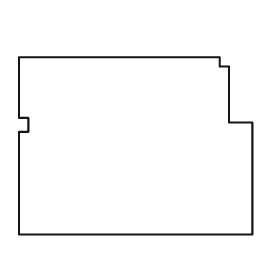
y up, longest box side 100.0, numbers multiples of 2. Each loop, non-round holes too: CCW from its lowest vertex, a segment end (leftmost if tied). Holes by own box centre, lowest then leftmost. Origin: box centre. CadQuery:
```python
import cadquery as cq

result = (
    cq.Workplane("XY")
    .moveTo(-50.0, -38.0)
    .lineTo(50.0, -38.0)
    .lineTo(50.0, 10.0)
    .lineTo(40.0, 10.0)
    .lineTo(40.0, 34.0)
    .lineTo(36.0, 34.0)
    .lineTo(36.0, 38.0)
    .lineTo(-50.0, 38.0)
    .lineTo(-50.0, 12.0)
    .lineTo(-46.0, 12.0)
    .lineTo(-46.0, 6.0)
    .lineTo(-50.0, 6.0)
    .close()
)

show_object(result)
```